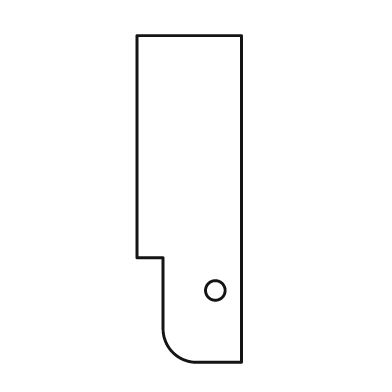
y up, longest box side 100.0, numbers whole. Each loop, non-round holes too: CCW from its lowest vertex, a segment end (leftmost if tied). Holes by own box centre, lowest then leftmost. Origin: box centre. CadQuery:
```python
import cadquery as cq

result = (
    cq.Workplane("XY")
    .moveTo(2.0, -50.0)
    .lineTo(16.0, -50.0)
    .lineTo(16.0, 50.0)
    .lineTo(-16.0, 50.0)
    .lineTo(-16.0, -18.0)
    .lineTo(-8.0, -18.0)
    .lineTo(-8.0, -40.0)
    .threePointArc((-5.0, -47.0), (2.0, -50.0))
    .close()
    .moveTo(8.0, -28.0)
    .circle(3.0)
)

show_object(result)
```